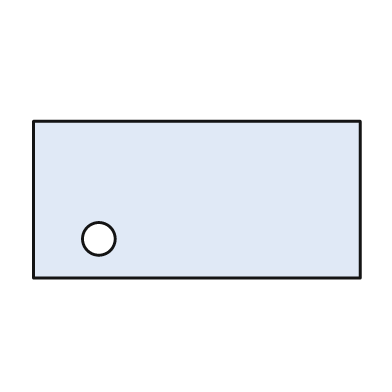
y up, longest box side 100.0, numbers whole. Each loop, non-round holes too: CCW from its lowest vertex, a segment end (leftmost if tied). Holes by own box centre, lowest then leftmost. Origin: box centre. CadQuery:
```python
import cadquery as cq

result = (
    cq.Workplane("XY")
    .moveTo(-50.0, -24.0)
    .lineTo(50.0, -24.0)
    .lineTo(50.0, 24.0)
    .lineTo(-50.0, 24.0)
    .close()
    .moveTo(-30.0, -12.0)
    .circle(5.0)
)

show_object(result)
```